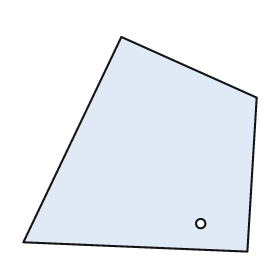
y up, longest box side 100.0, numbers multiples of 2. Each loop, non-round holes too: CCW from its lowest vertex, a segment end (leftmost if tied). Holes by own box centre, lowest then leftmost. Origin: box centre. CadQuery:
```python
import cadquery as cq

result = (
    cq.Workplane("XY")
    .moveTo(46.0, -46.0)
    .lineTo(50.0, 20.0)
    .lineTo(-8.0, 46.0)
    .lineTo(-50.0, -42.0)
    .close()
    .moveTo(26.0, -34.0)
    .circle(2.0)
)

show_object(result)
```